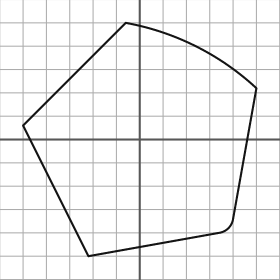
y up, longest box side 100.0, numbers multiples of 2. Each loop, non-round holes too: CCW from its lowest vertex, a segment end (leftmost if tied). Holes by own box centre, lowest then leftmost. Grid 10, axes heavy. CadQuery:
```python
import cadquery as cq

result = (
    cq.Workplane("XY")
    .moveTo(-22.0, -50.0)
    .lineTo(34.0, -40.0)
    .threePointArc((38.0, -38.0), (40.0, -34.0))
    .lineTo(50.0, 22.0)
    .threePointArc((24.0, 40.0), (-6.0, 50.0))
    .lineTo(-50.0, 6.0)
    .close()
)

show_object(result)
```